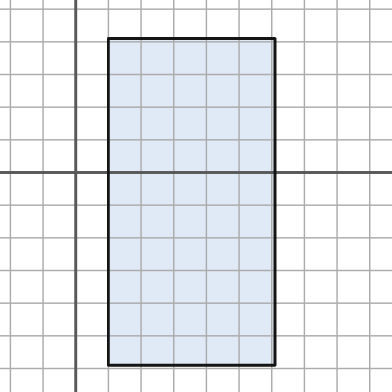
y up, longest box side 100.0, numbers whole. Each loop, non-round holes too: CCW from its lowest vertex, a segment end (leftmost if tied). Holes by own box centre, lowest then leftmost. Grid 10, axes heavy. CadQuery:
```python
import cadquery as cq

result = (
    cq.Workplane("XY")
    .moveTo(10.0, -59.0)
    .lineTo(61.0, -59.0)
    .lineTo(61.0, 41.0)
    .lineTo(10.0, 41.0)
    .close()
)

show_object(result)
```